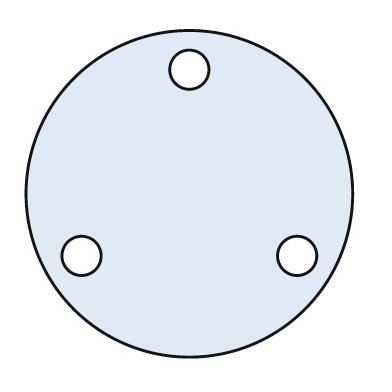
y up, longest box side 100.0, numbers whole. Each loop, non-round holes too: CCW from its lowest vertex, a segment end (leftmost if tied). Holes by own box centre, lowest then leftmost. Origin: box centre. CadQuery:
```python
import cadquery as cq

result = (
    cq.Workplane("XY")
    .moveTo(0.0, 0.0)
    .circle(50.0)
    .moveTo(-33.0, -19.0)
    .circle(6.0)
    .moveTo(33.0, -19.0)
    .circle(6.0)
    .moveTo(0.0, 38.0)
    .circle(6.0)
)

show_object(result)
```